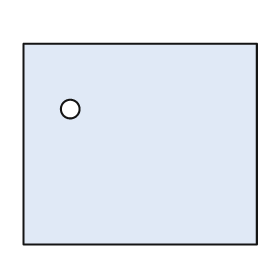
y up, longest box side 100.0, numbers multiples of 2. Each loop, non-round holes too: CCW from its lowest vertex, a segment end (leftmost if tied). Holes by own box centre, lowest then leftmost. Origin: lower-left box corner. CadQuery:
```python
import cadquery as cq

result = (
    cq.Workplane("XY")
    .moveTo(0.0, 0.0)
    .lineTo(100.0, 0.0)
    .lineTo(100.0, 86.0)
    .lineTo(0.0, 86.0)
    .close()
    .moveTo(20.0, 58.0)
    .circle(4.0)
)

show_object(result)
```